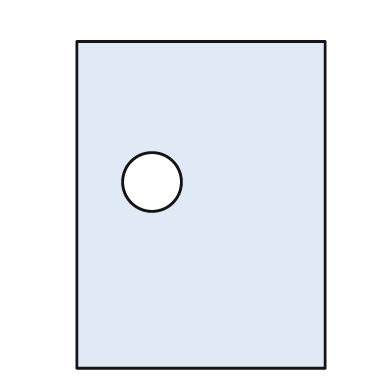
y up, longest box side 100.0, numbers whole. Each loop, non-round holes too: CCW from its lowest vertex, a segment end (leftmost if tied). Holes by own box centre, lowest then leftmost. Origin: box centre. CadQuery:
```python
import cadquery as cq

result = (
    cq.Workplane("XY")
    .moveTo(-38.0, -50.0)
    .lineTo(38.0, -50.0)
    .lineTo(38.0, 50.0)
    .lineTo(-38.0, 50.0)
    .close()
    .moveTo(-15.0, 7.0)
    .circle(9.0)
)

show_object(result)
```